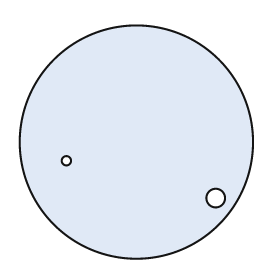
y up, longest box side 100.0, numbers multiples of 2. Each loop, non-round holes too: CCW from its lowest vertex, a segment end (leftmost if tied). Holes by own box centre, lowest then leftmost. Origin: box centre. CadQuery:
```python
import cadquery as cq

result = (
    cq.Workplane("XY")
    .moveTo(0.0, 0.0)
    .circle(50.0)
    .moveTo(34.0, -24.0)
    .circle(4.0)
    .moveTo(-30.0, -8.0)
    .circle(2.0)
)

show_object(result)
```